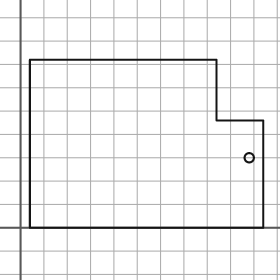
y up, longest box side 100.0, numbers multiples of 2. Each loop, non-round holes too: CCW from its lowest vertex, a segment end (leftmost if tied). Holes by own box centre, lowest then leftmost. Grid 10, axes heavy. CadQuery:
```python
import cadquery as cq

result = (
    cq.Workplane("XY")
    .moveTo(4.0, 0.0)
    .lineTo(104.0, 0.0)
    .lineTo(104.0, 46.0)
    .lineTo(84.0, 46.0)
    .lineTo(84.0, 72.0)
    .lineTo(4.0, 72.0)
    .close()
    .moveTo(98.0, 30.0)
    .circle(2.0)
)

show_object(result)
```